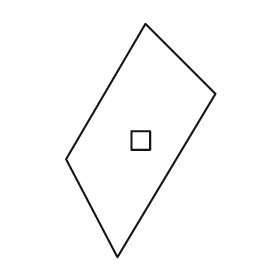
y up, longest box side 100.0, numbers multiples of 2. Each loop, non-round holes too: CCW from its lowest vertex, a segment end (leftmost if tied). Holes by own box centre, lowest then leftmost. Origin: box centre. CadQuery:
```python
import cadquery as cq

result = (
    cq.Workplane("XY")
    .moveTo(-10.0, -50.0)
    .lineTo(32.0, 20.0)
    .lineTo(2.0, 50.0)
    .lineTo(-32.0, -8.0)
    .close()
    .moveTo(-4.0, -4.0)
    .lineTo(4.0, -4.0)
    .lineTo(4.0, 4.0)
    .lineTo(-4.0, 4.0)
    .close()
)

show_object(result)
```